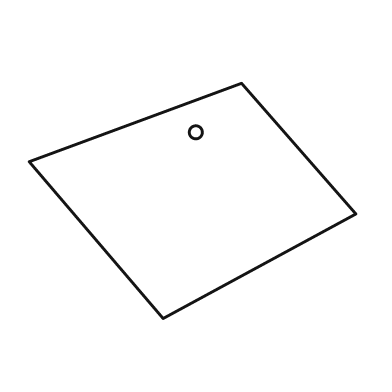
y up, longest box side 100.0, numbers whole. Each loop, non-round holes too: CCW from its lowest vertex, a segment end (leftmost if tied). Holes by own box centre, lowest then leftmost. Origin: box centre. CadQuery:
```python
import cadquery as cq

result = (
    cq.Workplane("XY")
    .moveTo(-9.0, -36.0)
    .lineTo(50.0, -4.0)
    .lineTo(15.0, 36.0)
    .lineTo(-50.0, 12.0)
    .close()
    .moveTo(1.0, 21.0)
    .circle(2.0)
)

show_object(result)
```